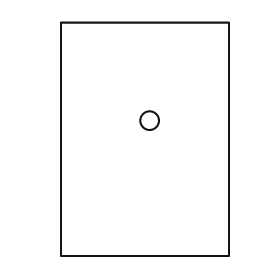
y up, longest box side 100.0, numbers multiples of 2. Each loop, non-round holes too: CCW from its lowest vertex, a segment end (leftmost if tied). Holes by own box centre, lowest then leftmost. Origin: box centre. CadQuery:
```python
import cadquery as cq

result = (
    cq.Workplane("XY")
    .moveTo(-36.0, -50.0)
    .lineTo(36.0, -50.0)
    .lineTo(36.0, 50.0)
    .lineTo(-36.0, 50.0)
    .close()
    .moveTo(2.0, 8.0)
    .circle(4.0)
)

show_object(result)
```